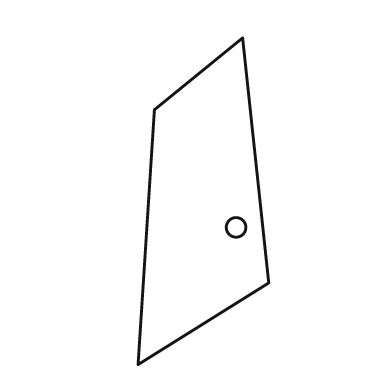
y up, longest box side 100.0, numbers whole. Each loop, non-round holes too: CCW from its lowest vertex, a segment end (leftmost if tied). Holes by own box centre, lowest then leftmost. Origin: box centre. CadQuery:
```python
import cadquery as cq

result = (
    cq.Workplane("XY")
    .moveTo(-20.0, -50.0)
    .lineTo(20.0, -25.0)
    .lineTo(12.0, 50.0)
    .lineTo(-15.0, 28.0)
    .close()
    .moveTo(10.0, -8.0)
    .circle(3.0)
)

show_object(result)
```